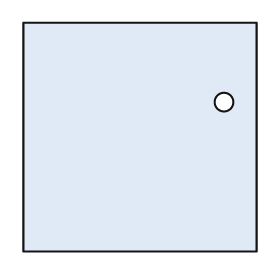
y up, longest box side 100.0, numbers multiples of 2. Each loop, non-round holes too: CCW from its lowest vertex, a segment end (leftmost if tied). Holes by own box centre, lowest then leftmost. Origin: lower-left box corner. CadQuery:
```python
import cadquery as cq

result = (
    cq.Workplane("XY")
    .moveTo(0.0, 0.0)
    .lineTo(100.0, 0.0)
    .lineTo(100.0, 98.0)
    .lineTo(0.0, 98.0)
    .close()
    .moveTo(86.0, 64.0)
    .circle(4.0)
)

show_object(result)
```